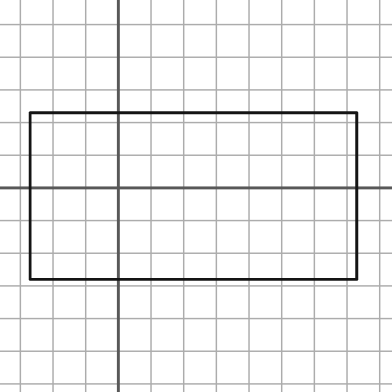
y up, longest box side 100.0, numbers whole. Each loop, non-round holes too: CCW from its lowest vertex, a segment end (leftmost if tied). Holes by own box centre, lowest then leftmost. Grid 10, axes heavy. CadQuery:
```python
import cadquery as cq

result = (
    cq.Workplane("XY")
    .moveTo(-27.0, -28.0)
    .lineTo(73.0, -28.0)
    .lineTo(73.0, 23.0)
    .lineTo(-27.0, 23.0)
    .close()
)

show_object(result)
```